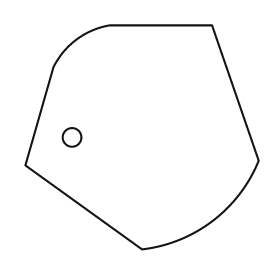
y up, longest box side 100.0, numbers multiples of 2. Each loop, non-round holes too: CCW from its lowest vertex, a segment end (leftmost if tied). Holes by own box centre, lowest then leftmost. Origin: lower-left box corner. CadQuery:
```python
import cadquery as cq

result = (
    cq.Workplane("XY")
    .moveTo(50.0, 0.0)
    .threePointArc((80.0, 12.0), (100.0, 38.0))
    .lineTo(80.0, 96.0)
    .lineTo(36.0, 96.0)
    .threePointArc((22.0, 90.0), (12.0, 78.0))
    .lineTo(0.0, 36.0)
    .close()
    .moveTo(20.0, 48.0)
    .circle(4.0)
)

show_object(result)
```